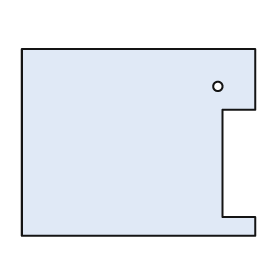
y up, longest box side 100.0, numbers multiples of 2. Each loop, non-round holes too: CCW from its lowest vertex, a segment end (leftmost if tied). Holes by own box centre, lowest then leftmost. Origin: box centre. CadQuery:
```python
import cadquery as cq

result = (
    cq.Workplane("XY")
    .moveTo(-50.0, -40.0)
    .lineTo(50.0, -40.0)
    .lineTo(50.0, -32.0)
    .lineTo(36.0, -32.0)
    .lineTo(36.0, 14.0)
    .lineTo(50.0, 14.0)
    .lineTo(50.0, 40.0)
    .lineTo(-50.0, 40.0)
    .close()
    .moveTo(34.0, 24.0)
    .circle(2.0)
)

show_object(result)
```